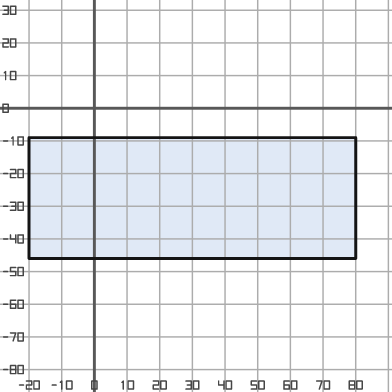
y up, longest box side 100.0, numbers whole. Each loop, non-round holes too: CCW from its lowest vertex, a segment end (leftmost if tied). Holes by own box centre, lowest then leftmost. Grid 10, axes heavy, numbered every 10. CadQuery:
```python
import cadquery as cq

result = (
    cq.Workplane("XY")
    .moveTo(-20.0, -46.0)
    .lineTo(80.0, -46.0)
    .lineTo(80.0, -9.0)
    .lineTo(-20.0, -9.0)
    .close()
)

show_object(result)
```